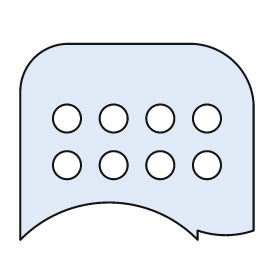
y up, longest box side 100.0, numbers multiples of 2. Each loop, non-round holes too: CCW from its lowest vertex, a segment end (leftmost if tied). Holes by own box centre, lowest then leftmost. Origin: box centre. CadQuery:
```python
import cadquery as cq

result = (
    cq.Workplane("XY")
    .moveTo(-50.0, -42.0)
    .threePointArc((-12.0, -26.0), (26.0, -42.0))
    .lineTo(26.0, -38.0)
    .threePointArc((38.0, -40.0), (50.0, -38.0))
    .lineTo(50.0, 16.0)
    .threePointArc((42.0, 34.0), (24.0, 42.0))
    .lineTo(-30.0, 42.0)
    .threePointArc((-44.0, 36.0), (-50.0, 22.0))
    .close()
    .moveTo(-30.0, -10.0)
    .circle(6.0)
    .moveTo(-10.0, -10.0)
    .circle(6.0)
    .moveTo(10.0, -10.0)
    .circle(6.0)
    .moveTo(30.0, -10.0)
    .circle(6.0)
    .moveTo(-30.0, 10.0)
    .circle(6.0)
    .moveTo(-10.0, 10.0)
    .circle(6.0)
    .moveTo(10.0, 10.0)
    .circle(6.0)
    .moveTo(30.0, 10.0)
    .circle(6.0)
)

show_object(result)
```